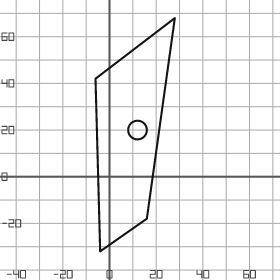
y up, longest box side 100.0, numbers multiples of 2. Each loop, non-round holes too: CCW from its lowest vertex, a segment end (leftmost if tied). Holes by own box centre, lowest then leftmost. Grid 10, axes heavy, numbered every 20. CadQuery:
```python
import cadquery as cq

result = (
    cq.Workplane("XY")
    .moveTo(-4.0, -32.0)
    .lineTo(16.0, -18.0)
    .lineTo(28.0, 68.0)
    .lineTo(-6.0, 42.0)
    .close()
    .moveTo(12.0, 20.0)
    .circle(4.0)
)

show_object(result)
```